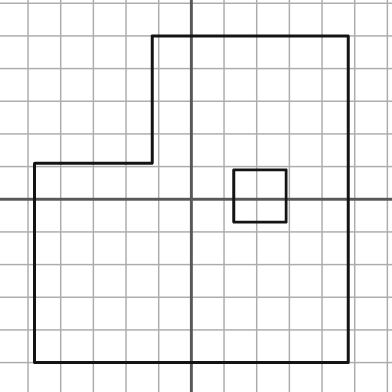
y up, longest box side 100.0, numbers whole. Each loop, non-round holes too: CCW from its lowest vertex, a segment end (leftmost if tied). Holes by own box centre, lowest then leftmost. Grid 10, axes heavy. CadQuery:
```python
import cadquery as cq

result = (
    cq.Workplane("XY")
    .moveTo(-48.0, -50.0)
    .lineTo(48.0, -50.0)
    .lineTo(48.0, 50.0)
    .lineTo(-12.0, 50.0)
    .lineTo(-12.0, 11.0)
    .lineTo(-48.0, 11.0)
    .close()
    .moveTo(13.0, -7.0)
    .lineTo(29.0, -7.0)
    .lineTo(29.0, 9.0)
    .lineTo(13.0, 9.0)
    .close()
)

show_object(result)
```